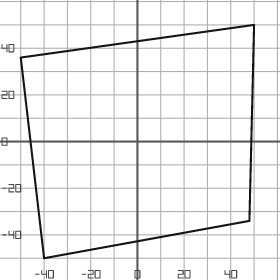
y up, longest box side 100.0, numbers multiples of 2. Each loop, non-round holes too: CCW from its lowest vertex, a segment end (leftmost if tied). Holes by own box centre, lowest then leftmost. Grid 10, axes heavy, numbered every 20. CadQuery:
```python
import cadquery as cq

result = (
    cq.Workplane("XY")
    .moveTo(-40.0, -50.0)
    .lineTo(48.0, -34.0)
    .lineTo(50.0, 50.0)
    .lineTo(-50.0, 36.0)
    .close()
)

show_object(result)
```